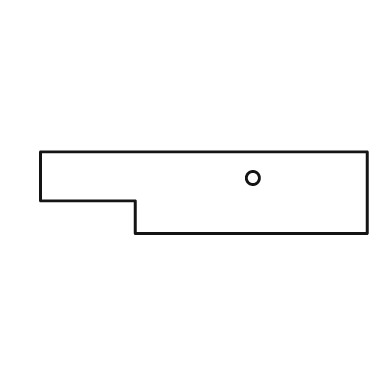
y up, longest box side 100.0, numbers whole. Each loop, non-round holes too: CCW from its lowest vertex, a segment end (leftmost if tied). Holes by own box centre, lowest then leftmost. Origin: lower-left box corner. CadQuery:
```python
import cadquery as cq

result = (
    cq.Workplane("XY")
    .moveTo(29.0, 0.0)
    .lineTo(100.0, 0.0)
    .lineTo(100.0, 25.0)
    .lineTo(0.0, 25.0)
    .lineTo(0.0, 10.0)
    .lineTo(29.0, 10.0)
    .close()
    .moveTo(65.0, 17.0)
    .circle(2.0)
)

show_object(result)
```